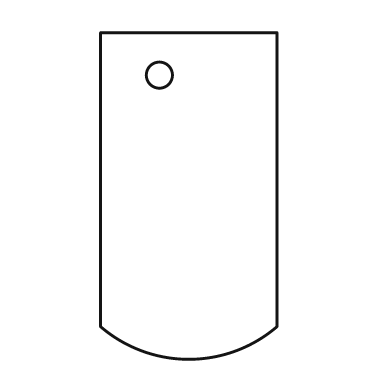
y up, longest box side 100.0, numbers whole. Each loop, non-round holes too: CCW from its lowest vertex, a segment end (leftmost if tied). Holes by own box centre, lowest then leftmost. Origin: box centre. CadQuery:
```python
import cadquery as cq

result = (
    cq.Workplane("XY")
    .moveTo(-27.0, -40.0)
    .threePointArc((0.0, -50.0), (27.0, -40.0))
    .lineTo(27.0, 50.0)
    .lineTo(-27.0, 50.0)
    .close()
    .moveTo(-9.0, 37.0)
    .circle(4.0)
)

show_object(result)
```